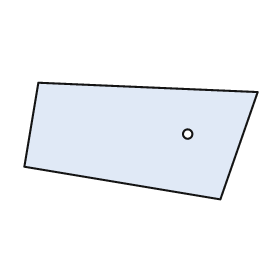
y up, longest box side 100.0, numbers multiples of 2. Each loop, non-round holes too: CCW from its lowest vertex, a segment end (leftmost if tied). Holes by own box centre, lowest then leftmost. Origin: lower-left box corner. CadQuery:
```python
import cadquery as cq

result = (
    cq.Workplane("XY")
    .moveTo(84.0, 0.0)
    .lineTo(100.0, 46.0)
    .lineTo(6.0, 50.0)
    .lineTo(0.0, 14.0)
    .close()
    .moveTo(70.0, 28.0)
    .circle(2.0)
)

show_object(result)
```